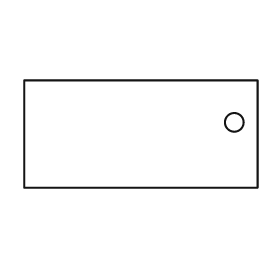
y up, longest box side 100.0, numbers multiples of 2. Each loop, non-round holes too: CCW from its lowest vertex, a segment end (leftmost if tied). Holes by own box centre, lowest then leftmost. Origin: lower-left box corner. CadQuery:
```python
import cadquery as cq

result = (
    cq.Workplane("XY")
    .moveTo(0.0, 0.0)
    .lineTo(100.0, 0.0)
    .lineTo(100.0, 46.0)
    .lineTo(0.0, 46.0)
    .close()
    .moveTo(90.0, 28.0)
    .circle(4.0)
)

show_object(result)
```